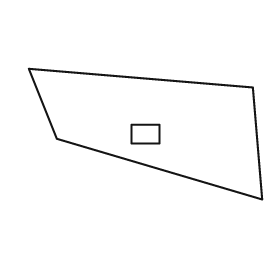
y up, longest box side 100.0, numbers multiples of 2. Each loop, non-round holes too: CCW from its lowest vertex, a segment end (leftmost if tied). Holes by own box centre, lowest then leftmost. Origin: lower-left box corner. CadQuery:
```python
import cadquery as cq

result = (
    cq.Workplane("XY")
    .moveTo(100.0, 0.0)
    .lineTo(96.0, 48.0)
    .lineTo(0.0, 56.0)
    .lineTo(12.0, 26.0)
    .close()
    .moveTo(44.0, 24.0)
    .lineTo(56.0, 24.0)
    .lineTo(56.0, 32.0)
    .lineTo(44.0, 32.0)
    .close()
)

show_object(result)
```